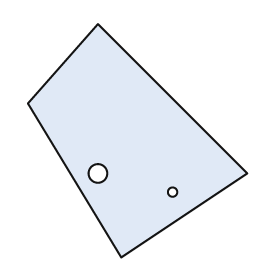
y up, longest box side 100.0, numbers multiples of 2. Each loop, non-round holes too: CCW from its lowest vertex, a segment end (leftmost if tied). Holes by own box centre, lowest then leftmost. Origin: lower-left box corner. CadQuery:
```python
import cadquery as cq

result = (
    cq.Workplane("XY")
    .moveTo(40.0, 0.0)
    .lineTo(94.0, 36.0)
    .lineTo(30.0, 100.0)
    .lineTo(0.0, 66.0)
    .close()
    .moveTo(62.0, 28.0)
    .circle(2.0)
    .moveTo(30.0, 36.0)
    .circle(4.0)
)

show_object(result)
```